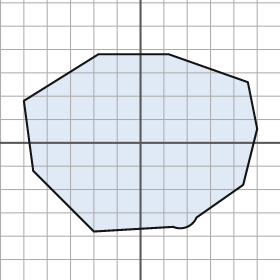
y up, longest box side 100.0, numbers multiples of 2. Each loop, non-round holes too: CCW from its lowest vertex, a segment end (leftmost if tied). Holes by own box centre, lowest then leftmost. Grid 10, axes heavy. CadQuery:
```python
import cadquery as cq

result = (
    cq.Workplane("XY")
    .moveTo(-20.0, -38.0)
    .lineTo(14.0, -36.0)
    .threePointArc((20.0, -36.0), (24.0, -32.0))
    .lineTo(44.0, -18.0)
    .lineTo(50.0, 6.0)
    .lineTo(46.0, 26.0)
    .lineTo(12.0, 38.0)
    .lineTo(-18.0, 38.0)
    .lineTo(-50.0, 18.0)
    .lineTo(-46.0, -12.0)
    .close()
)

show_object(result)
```